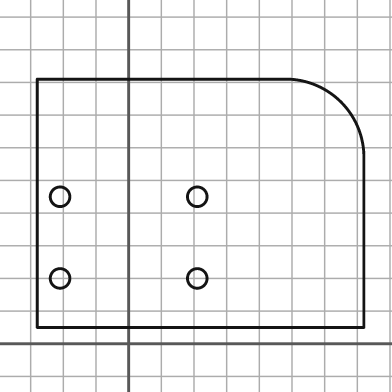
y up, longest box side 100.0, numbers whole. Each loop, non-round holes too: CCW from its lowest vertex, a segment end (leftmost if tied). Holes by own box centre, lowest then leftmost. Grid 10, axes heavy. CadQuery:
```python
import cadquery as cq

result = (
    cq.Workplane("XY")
    .moveTo(-28.0, 5.0)
    .lineTo(72.0, 5.0)
    .lineTo(72.0, 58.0)
    .threePointArc((65.0, 74.0), (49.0, 81.0))
    .lineTo(-28.0, 81.0)
    .close()
    .moveTo(-21.0, 20.0)
    .circle(3.0)
    .moveTo(21.0, 20.0)
    .circle(3.0)
    .moveTo(-21.0, 45.0)
    .circle(3.0)
    .moveTo(21.0, 45.0)
    .circle(3.0)
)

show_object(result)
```